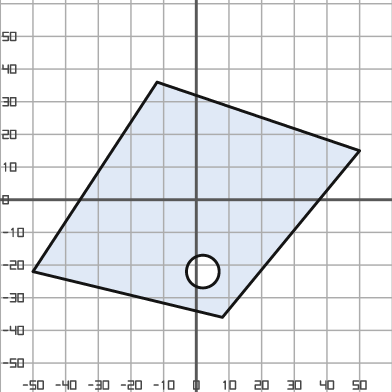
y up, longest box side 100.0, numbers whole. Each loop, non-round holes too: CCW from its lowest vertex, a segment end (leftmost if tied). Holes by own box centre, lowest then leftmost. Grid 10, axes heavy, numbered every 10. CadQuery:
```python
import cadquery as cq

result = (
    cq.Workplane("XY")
    .moveTo(8.0, -36.0)
    .lineTo(50.0, 15.0)
    .lineTo(-12.0, 36.0)
    .lineTo(-50.0, -22.0)
    .close()
    .moveTo(2.0, -22.0)
    .circle(5.0)
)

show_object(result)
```